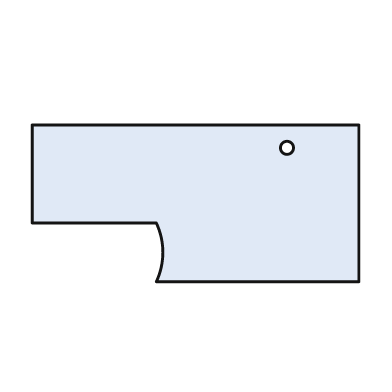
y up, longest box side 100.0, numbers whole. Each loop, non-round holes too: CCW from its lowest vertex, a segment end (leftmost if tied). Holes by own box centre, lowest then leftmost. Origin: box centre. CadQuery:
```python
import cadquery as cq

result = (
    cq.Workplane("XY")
    .moveTo(-12.0, -24.0)
    .lineTo(50.0, -24.0)
    .lineTo(50.0, 24.0)
    .lineTo(-50.0, 24.0)
    .lineTo(-50.0, -6.0)
    .lineTo(-12.0, -6.0)
    .threePointArc((-10.0, -15.0), (-12.0, -24.0))
    .close()
    .moveTo(28.0, 17.0)
    .circle(2.0)
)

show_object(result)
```